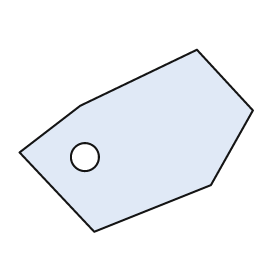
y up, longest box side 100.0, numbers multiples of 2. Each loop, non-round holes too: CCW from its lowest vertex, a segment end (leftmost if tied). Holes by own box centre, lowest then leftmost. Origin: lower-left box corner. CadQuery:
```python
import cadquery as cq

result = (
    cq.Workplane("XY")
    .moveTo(32.0, 0.0)
    .lineTo(82.0, 20.0)
    .lineTo(100.0, 52.0)
    .lineTo(76.0, 78.0)
    .lineTo(26.0, 54.0)
    .lineTo(0.0, 34.0)
    .close()
    .moveTo(28.0, 32.0)
    .circle(6.0)
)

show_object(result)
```